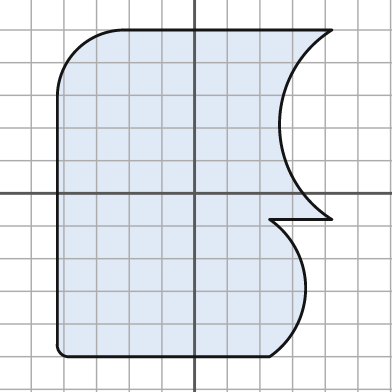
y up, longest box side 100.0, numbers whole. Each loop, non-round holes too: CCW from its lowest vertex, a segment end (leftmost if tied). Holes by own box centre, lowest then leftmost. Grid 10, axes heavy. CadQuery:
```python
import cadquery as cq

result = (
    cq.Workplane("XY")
    .moveTo(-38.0, -50.0)
    .lineTo(23.0, -50.0)
    .threePointArc((34.0, -29.0), (23.0, -8.0))
    .lineTo(42.0, -8.0)
    .threePointArc((26.0, 21.0), (42.0, 50.0))
    .lineTo(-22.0, 50.0)
    .threePointArc((-36.0, 44.0), (-42.0, 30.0))
    .lineTo(-42.0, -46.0)
    .threePointArc((-41.0, -49.0), (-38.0, -50.0))
    .close()
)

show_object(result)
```